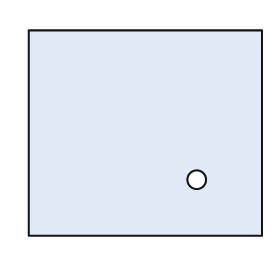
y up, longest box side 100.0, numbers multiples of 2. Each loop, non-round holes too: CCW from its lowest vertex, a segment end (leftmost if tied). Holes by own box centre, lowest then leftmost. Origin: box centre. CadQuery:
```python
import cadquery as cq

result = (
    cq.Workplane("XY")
    .moveTo(-50.0, -44.0)
    .lineTo(50.0, -44.0)
    .lineTo(50.0, 44.0)
    .lineTo(-50.0, 44.0)
    .close()
    .moveTo(22.0, -20.0)
    .circle(4.0)
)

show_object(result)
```